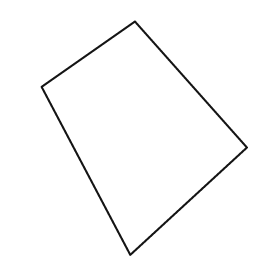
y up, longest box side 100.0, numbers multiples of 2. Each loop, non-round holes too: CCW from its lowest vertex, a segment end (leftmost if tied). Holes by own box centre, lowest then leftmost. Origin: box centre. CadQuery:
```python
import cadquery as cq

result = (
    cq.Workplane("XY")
    .moveTo(-6.0, -50.0)
    .lineTo(44.0, -4.0)
    .lineTo(-4.0, 50.0)
    .lineTo(-44.0, 22.0)
    .close()
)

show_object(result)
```